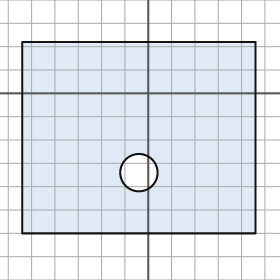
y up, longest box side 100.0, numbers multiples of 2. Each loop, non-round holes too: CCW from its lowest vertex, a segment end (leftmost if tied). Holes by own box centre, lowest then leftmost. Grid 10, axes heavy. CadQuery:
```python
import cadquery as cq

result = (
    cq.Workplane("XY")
    .moveTo(-54.0, -60.0)
    .lineTo(46.0, -60.0)
    .lineTo(46.0, 22.0)
    .lineTo(-54.0, 22.0)
    .close()
    .moveTo(-4.0, -34.0)
    .circle(8.0)
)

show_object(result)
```